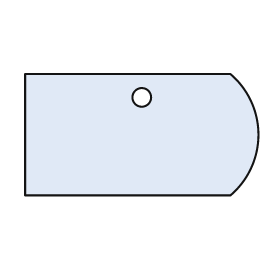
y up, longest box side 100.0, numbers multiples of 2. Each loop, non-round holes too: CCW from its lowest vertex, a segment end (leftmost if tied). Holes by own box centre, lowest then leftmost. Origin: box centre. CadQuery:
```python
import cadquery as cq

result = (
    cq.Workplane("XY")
    .moveTo(-50.0, -26.0)
    .lineTo(38.0, -26.0)
    .threePointArc((50.0, 0.0), (38.0, 26.0))
    .lineTo(-50.0, 26.0)
    .close()
    .moveTo(0.0, 16.0)
    .circle(4.0)
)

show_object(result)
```